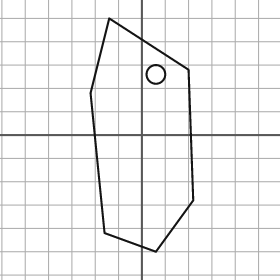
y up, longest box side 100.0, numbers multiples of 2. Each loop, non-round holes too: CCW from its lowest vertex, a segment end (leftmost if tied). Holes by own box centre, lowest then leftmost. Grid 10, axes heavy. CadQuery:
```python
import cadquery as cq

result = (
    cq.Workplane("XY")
    .moveTo(6.0, -50.0)
    .lineTo(22.0, -28.0)
    .lineTo(20.0, 28.0)
    .lineTo(-14.0, 50.0)
    .lineTo(-22.0, 18.0)
    .lineTo(-16.0, -42.0)
    .close()
    .moveTo(6.0, 26.0)
    .circle(4.0)
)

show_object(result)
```